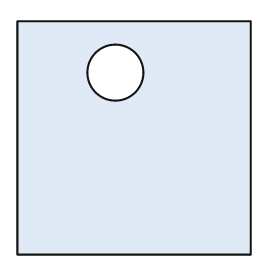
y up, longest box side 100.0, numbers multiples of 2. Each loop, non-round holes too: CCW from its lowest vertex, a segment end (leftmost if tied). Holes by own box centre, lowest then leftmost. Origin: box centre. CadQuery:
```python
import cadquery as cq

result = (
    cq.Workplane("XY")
    .moveTo(-50.0, -50.0)
    .lineTo(50.0, -50.0)
    .lineTo(50.0, 50.0)
    .lineTo(-50.0, 50.0)
    .close()
    .moveTo(-8.0, 28.0)
    .circle(12.0)
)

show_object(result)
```